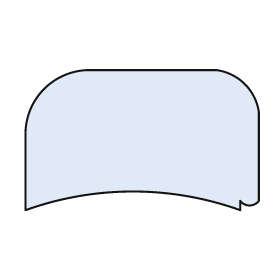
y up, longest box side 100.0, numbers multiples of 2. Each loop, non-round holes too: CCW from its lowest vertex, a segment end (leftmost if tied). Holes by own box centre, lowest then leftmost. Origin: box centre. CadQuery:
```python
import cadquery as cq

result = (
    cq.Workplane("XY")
    .moveTo(-50.0, -30.0)
    .threePointArc((-4.0, -22.0), (42.0, -30.0))
    .lineTo(42.0, -26.0)
    .threePointArc((46.0, -28.0), (50.0, -26.0))
    .lineTo(50.0, 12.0)
    .threePointArc((44.0, 24.0), (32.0, 30.0))
    .lineTo(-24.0, 30.0)
    .threePointArc((-42.0, 22.0), (-50.0, 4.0))
    .close()
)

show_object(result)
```